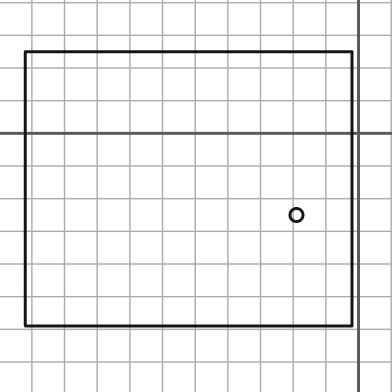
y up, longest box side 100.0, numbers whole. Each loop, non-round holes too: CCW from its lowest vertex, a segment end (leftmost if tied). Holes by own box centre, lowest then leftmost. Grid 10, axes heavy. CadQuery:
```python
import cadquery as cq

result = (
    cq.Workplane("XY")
    .moveTo(-102.0, -59.0)
    .lineTo(-2.0, -59.0)
    .lineTo(-2.0, 25.0)
    .lineTo(-102.0, 25.0)
    .close()
    .moveTo(-19.0, -25.0)
    .circle(2.0)
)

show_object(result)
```